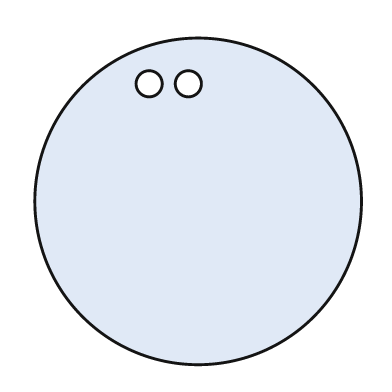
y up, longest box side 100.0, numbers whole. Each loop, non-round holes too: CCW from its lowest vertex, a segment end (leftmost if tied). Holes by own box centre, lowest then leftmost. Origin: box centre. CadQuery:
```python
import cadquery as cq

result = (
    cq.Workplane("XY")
    .moveTo(0.0, 0.0)
    .circle(50.0)
    .moveTo(-15.0, 36.0)
    .circle(4.0)
    .moveTo(-3.0, 36.0)
    .circle(4.0)
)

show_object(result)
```